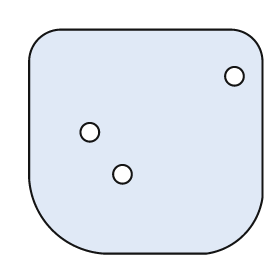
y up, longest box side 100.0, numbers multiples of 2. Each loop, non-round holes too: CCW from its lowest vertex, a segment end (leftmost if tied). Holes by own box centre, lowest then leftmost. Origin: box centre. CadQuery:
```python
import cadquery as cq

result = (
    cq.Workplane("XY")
    .moveTo(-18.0, -48.0)
    .lineTo(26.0, -48.0)
    .threePointArc((42.0, -40.0), (50.0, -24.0))
    .lineTo(50.0, 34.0)
    .threePointArc((46.0, 44.0), (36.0, 48.0))
    .lineTo(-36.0, 48.0)
    .threePointArc((-46.0, 44.0), (-50.0, 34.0))
    .lineTo(-50.0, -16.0)
    .threePointArc((-40.0, -38.0), (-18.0, -48.0))
    .close()
    .moveTo(-10.0, -14.0)
    .circle(4.0)
    .moveTo(-24.0, 4.0)
    .circle(4.0)
    .moveTo(38.0, 28.0)
    .circle(4.0)
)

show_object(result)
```